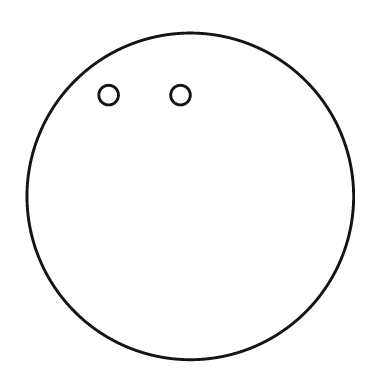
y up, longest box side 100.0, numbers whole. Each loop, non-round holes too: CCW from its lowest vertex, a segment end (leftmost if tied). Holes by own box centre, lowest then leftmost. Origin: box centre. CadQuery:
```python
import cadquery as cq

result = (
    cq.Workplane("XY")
    .moveTo(0.0, 0.0)
    .circle(50.0)
    .moveTo(-25.0, 31.0)
    .circle(3.0)
    .moveTo(-3.0, 31.0)
    .circle(3.0)
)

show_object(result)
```